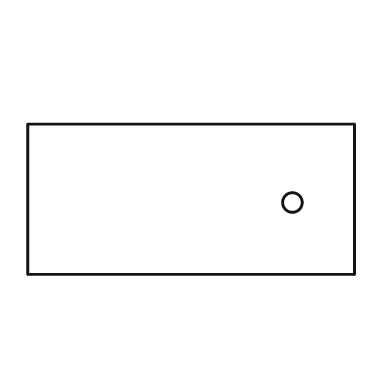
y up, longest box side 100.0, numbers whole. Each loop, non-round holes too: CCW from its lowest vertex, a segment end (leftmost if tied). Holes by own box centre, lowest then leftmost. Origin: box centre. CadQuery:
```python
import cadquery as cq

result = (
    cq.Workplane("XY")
    .moveTo(-50.0, -23.0)
    .lineTo(50.0, -23.0)
    .lineTo(50.0, 23.0)
    .lineTo(-50.0, 23.0)
    .close()
    .moveTo(31.0, -1.0)
    .circle(3.0)
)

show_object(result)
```